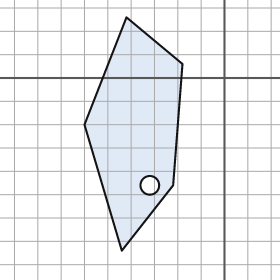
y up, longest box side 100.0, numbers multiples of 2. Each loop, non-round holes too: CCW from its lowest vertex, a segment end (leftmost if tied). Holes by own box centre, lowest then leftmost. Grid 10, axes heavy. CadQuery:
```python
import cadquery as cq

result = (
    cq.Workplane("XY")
    .moveTo(-44.0, -74.0)
    .lineTo(-22.0, -46.0)
    .lineTo(-18.0, 6.0)
    .lineTo(-42.0, 26.0)
    .lineTo(-60.0, -20.0)
    .close()
    .moveTo(-32.0, -46.0)
    .circle(4.0)
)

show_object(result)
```